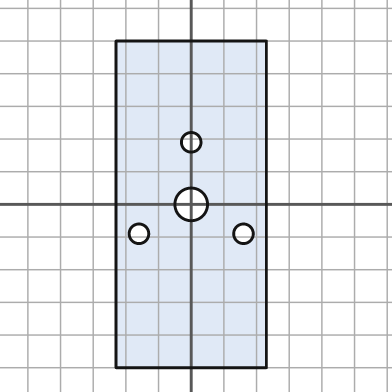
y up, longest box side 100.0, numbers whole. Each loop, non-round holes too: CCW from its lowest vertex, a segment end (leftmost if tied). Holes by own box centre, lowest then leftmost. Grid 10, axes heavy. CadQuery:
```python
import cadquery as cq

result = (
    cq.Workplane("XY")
    .moveTo(-23.0, -50.0)
    .lineTo(23.0, -50.0)
    .lineTo(23.0, 50.0)
    .lineTo(-23.0, 50.0)
    .close()
    .moveTo(-16.0, -9.0)
    .circle(3.0)
    .moveTo(16.0, -9.0)
    .circle(3.0)
    .moveTo(0.0, 0.0)
    .circle(5.0)
    .moveTo(0.0, 19.0)
    .circle(3.0)
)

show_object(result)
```